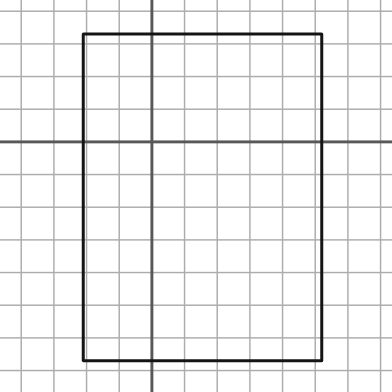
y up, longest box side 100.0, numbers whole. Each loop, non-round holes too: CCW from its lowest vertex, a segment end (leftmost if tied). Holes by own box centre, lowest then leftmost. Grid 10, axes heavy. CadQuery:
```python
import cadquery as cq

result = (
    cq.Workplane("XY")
    .moveTo(-21.0, -67.0)
    .lineTo(52.0, -67.0)
    .lineTo(52.0, 33.0)
    .lineTo(-21.0, 33.0)
    .close()
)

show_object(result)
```